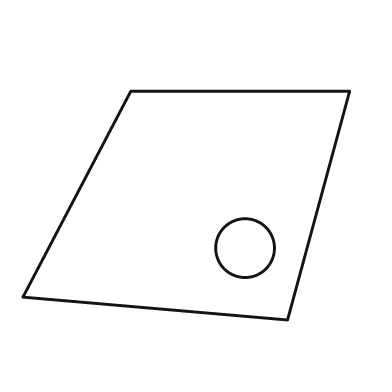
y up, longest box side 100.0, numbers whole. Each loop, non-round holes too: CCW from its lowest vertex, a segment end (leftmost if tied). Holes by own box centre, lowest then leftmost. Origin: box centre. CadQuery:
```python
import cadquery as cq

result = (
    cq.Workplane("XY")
    .moveTo(31.0, -35.0)
    .lineTo(50.0, 35.0)
    .lineTo(-17.0, 35.0)
    .lineTo(-50.0, -28.0)
    .close()
    .moveTo(18.0, -13.0)
    .circle(9.0)
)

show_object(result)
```